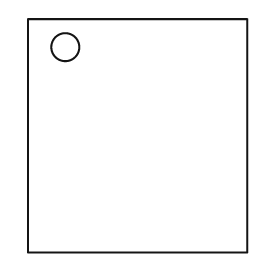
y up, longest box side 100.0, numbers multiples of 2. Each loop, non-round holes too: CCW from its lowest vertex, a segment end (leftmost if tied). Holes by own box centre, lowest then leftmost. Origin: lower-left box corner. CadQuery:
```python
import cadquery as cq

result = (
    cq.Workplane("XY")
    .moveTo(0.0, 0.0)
    .lineTo(94.0, 0.0)
    .lineTo(94.0, 100.0)
    .lineTo(0.0, 100.0)
    .close()
    .moveTo(16.0, 88.0)
    .circle(6.0)
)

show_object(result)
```